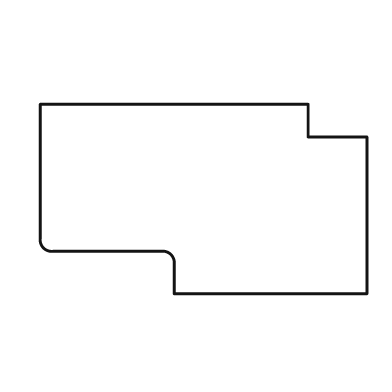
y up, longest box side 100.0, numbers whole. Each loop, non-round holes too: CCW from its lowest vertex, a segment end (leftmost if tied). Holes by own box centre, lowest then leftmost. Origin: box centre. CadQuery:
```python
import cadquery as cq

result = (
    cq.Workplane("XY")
    .moveTo(-9.0, -29.0)
    .lineTo(50.0, -29.0)
    .lineTo(50.0, 19.0)
    .lineTo(32.0, 19.0)
    .lineTo(32.0, 29.0)
    .lineTo(-50.0, 29.0)
    .lineTo(-50.0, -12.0)
    .threePointArc((-49.0, -15.0), (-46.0, -16.0))
    .lineTo(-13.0, -16.0)
    .threePointArc((-10.0, -17.0), (-9.0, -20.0))
    .close()
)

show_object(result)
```